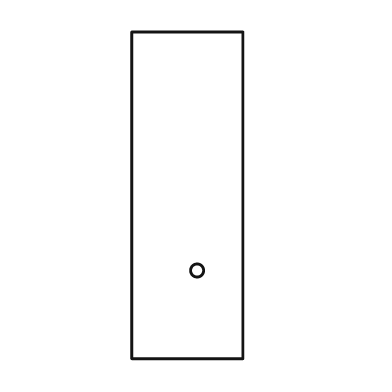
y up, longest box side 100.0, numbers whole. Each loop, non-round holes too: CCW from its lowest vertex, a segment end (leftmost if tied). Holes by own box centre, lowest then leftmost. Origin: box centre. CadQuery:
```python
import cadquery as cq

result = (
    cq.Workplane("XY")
    .moveTo(-17.0, -50.0)
    .lineTo(17.0, -50.0)
    .lineTo(17.0, 50.0)
    .lineTo(-17.0, 50.0)
    .close()
    .moveTo(3.0, -23.0)
    .circle(2.0)
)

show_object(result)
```